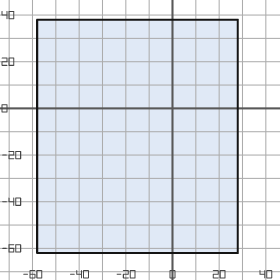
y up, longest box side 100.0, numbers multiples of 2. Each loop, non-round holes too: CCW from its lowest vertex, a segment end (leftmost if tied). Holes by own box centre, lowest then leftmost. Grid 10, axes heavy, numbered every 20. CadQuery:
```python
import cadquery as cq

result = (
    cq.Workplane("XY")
    .moveTo(-58.0, -62.0)
    .lineTo(28.0, -62.0)
    .lineTo(28.0, 38.0)
    .lineTo(-58.0, 38.0)
    .close()
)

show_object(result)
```